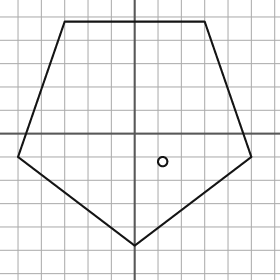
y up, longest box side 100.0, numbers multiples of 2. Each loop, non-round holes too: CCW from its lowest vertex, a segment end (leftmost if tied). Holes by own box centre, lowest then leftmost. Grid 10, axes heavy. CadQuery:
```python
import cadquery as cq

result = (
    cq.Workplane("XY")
    .moveTo(0.0, -48.0)
    .lineTo(50.0, -10.0)
    .lineTo(30.0, 48.0)
    .lineTo(-30.0, 48.0)
    .lineTo(-50.0, -10.0)
    .close()
    .moveTo(12.0, -12.0)
    .circle(2.0)
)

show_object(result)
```